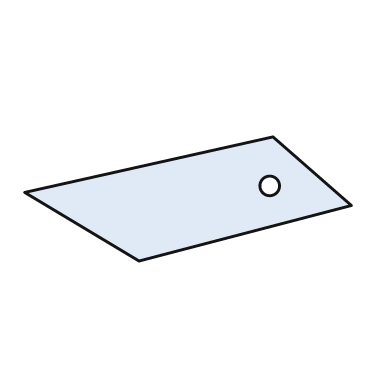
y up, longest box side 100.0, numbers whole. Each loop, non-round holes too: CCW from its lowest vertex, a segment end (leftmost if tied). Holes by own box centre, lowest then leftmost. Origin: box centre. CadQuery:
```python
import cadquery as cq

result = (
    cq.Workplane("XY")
    .moveTo(-15.0, -19.0)
    .lineTo(50.0, -2.0)
    .lineTo(26.0, 19.0)
    .lineTo(-50.0, 2.0)
    .close()
    .moveTo(25.0, 4.0)
    .circle(3.0)
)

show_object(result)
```